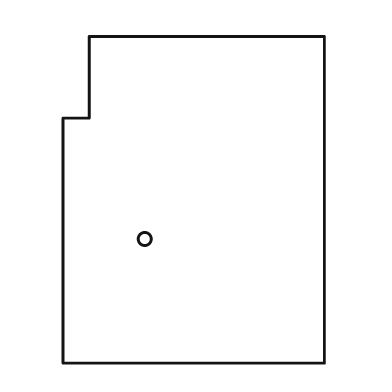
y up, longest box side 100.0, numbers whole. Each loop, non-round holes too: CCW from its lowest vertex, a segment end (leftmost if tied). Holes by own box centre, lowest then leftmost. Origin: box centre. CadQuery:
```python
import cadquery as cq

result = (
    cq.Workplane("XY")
    .moveTo(-40.0, -50.0)
    .lineTo(40.0, -50.0)
    .lineTo(40.0, 50.0)
    .lineTo(-32.0, 50.0)
    .lineTo(-32.0, 25.0)
    .lineTo(-40.0, 25.0)
    .close()
    .moveTo(-15.0, -12.0)
    .circle(2.0)
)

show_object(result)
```